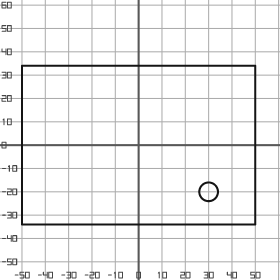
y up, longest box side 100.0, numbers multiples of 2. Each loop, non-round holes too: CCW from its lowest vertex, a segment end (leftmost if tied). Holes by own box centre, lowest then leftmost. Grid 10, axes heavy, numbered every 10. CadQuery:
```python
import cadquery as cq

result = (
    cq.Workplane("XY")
    .moveTo(-50.0, -34.0)
    .lineTo(50.0, -34.0)
    .lineTo(50.0, 34.0)
    .lineTo(-50.0, 34.0)
    .close()
    .moveTo(30.0, -20.0)
    .circle(4.0)
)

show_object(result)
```